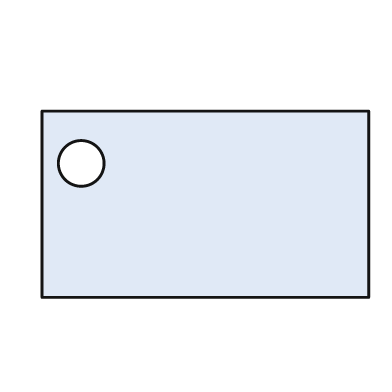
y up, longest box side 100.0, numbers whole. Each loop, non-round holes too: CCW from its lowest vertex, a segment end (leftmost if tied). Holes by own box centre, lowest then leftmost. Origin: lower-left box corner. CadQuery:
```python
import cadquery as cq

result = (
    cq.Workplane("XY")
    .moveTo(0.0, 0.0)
    .lineTo(100.0, 0.0)
    .lineTo(100.0, 57.0)
    .lineTo(0.0, 57.0)
    .close()
    .moveTo(12.0, 41.0)
    .circle(7.0)
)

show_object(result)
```